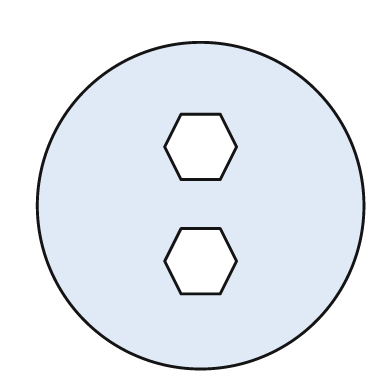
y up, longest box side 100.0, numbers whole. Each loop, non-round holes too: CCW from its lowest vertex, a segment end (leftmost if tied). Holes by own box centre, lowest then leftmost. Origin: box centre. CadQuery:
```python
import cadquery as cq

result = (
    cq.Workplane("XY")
    .moveTo(0.0, 0.0)
    .circle(50.0)
    .moveTo(-6.0, -27.0)
    .lineTo(6.0, -27.0)
    .lineTo(11.0, -17.0)
    .lineTo(6.0, -7.0)
    .lineTo(-6.0, -7.0)
    .lineTo(-11.0, -17.0)
    .close()
    .moveTo(-6.0, 8.0)
    .lineTo(6.0, 8.0)
    .lineTo(11.0, 18.0)
    .lineTo(6.0, 28.0)
    .lineTo(-6.0, 28.0)
    .lineTo(-11.0, 18.0)
    .close()
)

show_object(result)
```